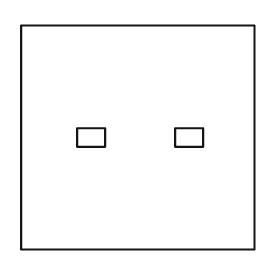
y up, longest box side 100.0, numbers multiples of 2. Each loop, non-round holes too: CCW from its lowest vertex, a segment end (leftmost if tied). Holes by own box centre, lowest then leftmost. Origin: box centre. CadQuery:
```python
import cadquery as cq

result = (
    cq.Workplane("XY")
    .moveTo(-50.0, -48.0)
    .lineTo(50.0, -48.0)
    .lineTo(50.0, 48.0)
    .lineTo(-50.0, 48.0)
    .close()
    .moveTo(-26.0, -4.0)
    .lineTo(-14.0, -4.0)
    .lineTo(-14.0, 4.0)
    .lineTo(-26.0, 4.0)
    .close()
    .moveTo(16.0, -4.0)
    .lineTo(28.0, -4.0)
    .lineTo(28.0, 4.0)
    .lineTo(16.0, 4.0)
    .close()
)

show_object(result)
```